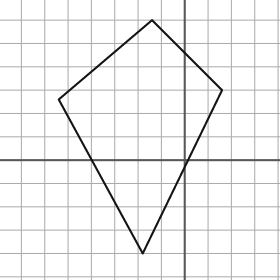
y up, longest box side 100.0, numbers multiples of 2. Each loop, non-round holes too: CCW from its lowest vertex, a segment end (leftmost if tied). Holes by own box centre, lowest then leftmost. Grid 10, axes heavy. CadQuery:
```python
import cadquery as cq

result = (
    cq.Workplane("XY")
    .moveTo(-18.0, -40.0)
    .lineTo(16.0, 30.0)
    .lineTo(-14.0, 60.0)
    .lineTo(-54.0, 26.0)
    .close()
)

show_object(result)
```